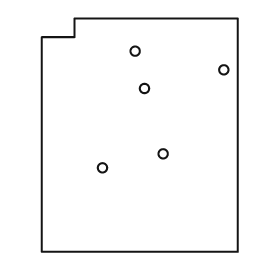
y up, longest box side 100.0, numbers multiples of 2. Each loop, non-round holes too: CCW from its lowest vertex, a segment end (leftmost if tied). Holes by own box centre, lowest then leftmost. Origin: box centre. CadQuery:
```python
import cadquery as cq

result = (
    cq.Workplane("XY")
    .moveTo(-42.0, -50.0)
    .lineTo(42.0, -50.0)
    .lineTo(42.0, 50.0)
    .lineTo(-28.0, 50.0)
    .lineTo(-28.0, 42.0)
    .lineTo(-42.0, 42.0)
    .close()
    .moveTo(-16.0, -14.0)
    .circle(2.0)
    .moveTo(10.0, -8.0)
    .circle(2.0)
    .moveTo(2.0, 20.0)
    .circle(2.0)
    .moveTo(36.0, 28.0)
    .circle(2.0)
    .moveTo(-2.0, 36.0)
    .circle(2.0)
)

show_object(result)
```